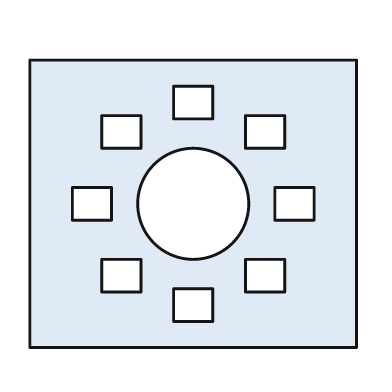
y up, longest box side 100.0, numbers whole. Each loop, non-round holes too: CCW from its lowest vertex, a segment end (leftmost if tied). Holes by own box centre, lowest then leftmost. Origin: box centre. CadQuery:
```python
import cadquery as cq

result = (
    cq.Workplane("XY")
    .moveTo(-50.0, -44.0)
    .lineTo(50.0, -44.0)
    .lineTo(50.0, 44.0)
    .lineTo(-50.0, 44.0)
    .close()
    .moveTo(-6.0, -36.0)
    .lineTo(6.0, -36.0)
    .lineTo(6.0, -26.0)
    .lineTo(-6.0, -26.0)
    .close()
    .moveTo(-28.0, -27.0)
    .lineTo(-16.0, -27.0)
    .lineTo(-16.0, -17.0)
    .lineTo(-28.0, -17.0)
    .close()
    .moveTo(16.0, -27.0)
    .lineTo(28.0, -27.0)
    .lineTo(28.0, -17.0)
    .lineTo(16.0, -17.0)
    .close()
    .moveTo(-37.0, -5.0)
    .lineTo(-25.0, -5.0)
    .lineTo(-25.0, 5.0)
    .lineTo(-37.0, 5.0)
    .close()
    .moveTo(0.0, 0.0)
    .circle(17.0)
    .moveTo(25.0, -5.0)
    .lineTo(37.0, -5.0)
    .lineTo(37.0, 5.0)
    .lineTo(25.0, 5.0)
    .close()
    .moveTo(-28.0, 17.0)
    .lineTo(-16.0, 17.0)
    .lineTo(-16.0, 27.0)
    .lineTo(-28.0, 27.0)
    .close()
    .moveTo(16.0, 17.0)
    .lineTo(28.0, 17.0)
    .lineTo(28.0, 27.0)
    .lineTo(16.0, 27.0)
    .close()
    .moveTo(-6.0, 26.0)
    .lineTo(6.0, 26.0)
    .lineTo(6.0, 36.0)
    .lineTo(-6.0, 36.0)
    .close()
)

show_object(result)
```